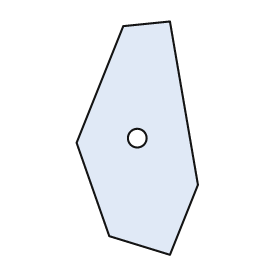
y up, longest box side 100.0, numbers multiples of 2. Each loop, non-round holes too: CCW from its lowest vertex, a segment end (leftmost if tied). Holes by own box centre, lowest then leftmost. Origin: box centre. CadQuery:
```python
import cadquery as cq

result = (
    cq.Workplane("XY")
    .moveTo(14.0, -50.0)
    .lineTo(26.0, -20.0)
    .lineTo(14.0, 50.0)
    .lineTo(-6.0, 48.0)
    .lineTo(-26.0, -2.0)
    .lineTo(-12.0, -42.0)
    .close()
    .moveTo(0.0, 0.0)
    .circle(4.0)
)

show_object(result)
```